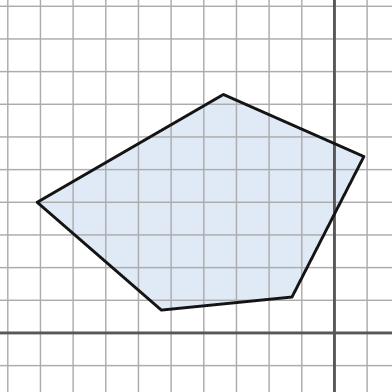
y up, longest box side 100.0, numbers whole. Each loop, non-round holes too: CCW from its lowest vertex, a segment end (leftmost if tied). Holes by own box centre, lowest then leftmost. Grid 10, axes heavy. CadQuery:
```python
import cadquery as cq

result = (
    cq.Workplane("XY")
    .moveTo(-53.0, 7.0)
    .lineTo(-13.0, 11.0)
    .lineTo(9.0, 54.0)
    .lineTo(-34.0, 73.0)
    .lineTo(-91.0, 40.0)
    .close()
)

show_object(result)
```